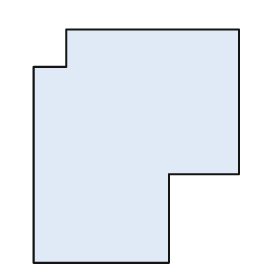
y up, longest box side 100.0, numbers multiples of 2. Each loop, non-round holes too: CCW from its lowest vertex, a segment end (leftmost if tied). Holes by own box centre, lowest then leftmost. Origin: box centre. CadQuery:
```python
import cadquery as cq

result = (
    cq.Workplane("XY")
    .moveTo(-44.0, -50.0)
    .lineTo(14.0, -50.0)
    .lineTo(14.0, -12.0)
    .lineTo(44.0, -12.0)
    .lineTo(44.0, 50.0)
    .lineTo(-30.0, 50.0)
    .lineTo(-30.0, 34.0)
    .lineTo(-44.0, 34.0)
    .close()
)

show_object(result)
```